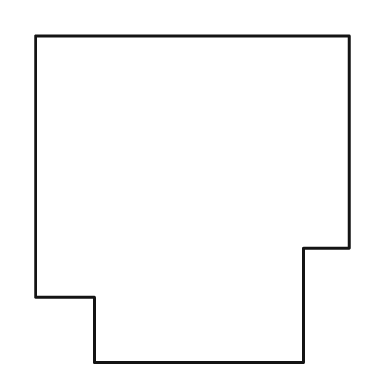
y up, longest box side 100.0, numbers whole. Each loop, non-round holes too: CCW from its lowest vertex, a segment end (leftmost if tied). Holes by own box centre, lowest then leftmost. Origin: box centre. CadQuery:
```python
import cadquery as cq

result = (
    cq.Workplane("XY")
    .moveTo(-30.0, -50.0)
    .lineTo(34.0, -50.0)
    .lineTo(34.0, -15.0)
    .lineTo(48.0, -15.0)
    .lineTo(48.0, 50.0)
    .lineTo(-48.0, 50.0)
    .lineTo(-48.0, -30.0)
    .lineTo(-30.0, -30.0)
    .close()
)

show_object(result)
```